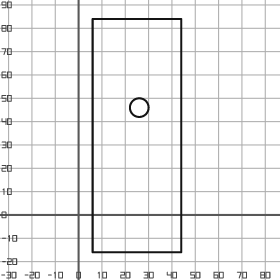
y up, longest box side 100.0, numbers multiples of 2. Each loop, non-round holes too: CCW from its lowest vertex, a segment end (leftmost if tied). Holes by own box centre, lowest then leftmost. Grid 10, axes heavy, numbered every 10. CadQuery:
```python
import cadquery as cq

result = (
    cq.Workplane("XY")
    .moveTo(6.0, -16.0)
    .lineTo(44.0, -16.0)
    .lineTo(44.0, 84.0)
    .lineTo(6.0, 84.0)
    .close()
    .moveTo(26.0, 46.0)
    .circle(4.0)
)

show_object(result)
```